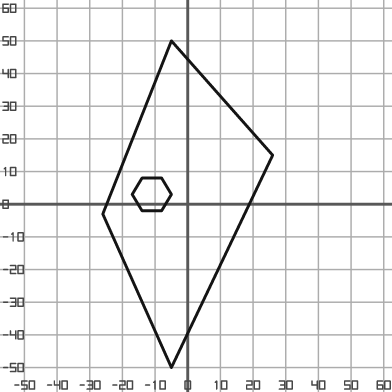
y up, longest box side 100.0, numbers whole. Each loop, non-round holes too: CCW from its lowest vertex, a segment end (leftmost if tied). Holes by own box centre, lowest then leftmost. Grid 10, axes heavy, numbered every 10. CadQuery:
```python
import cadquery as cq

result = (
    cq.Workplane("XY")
    .moveTo(-5.0, -50.0)
    .lineTo(26.0, 15.0)
    .lineTo(-5.0, 50.0)
    .lineTo(-26.0, -3.0)
    .close()
    .moveTo(-14.0, -2.0)
    .lineTo(-8.0, -2.0)
    .lineTo(-5.0, 3.0)
    .lineTo(-8.0, 8.0)
    .lineTo(-14.0, 8.0)
    .lineTo(-17.0, 3.0)
    .close()
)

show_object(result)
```